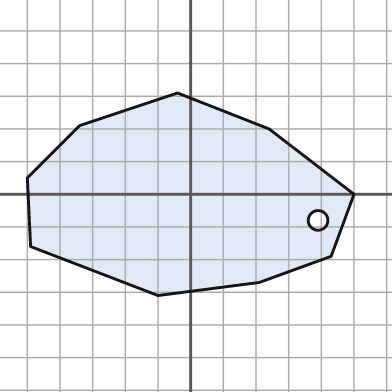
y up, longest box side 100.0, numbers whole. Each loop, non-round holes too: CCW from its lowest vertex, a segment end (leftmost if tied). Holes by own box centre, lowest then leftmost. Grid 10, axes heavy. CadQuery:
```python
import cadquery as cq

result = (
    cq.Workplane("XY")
    .moveTo(-10.0, -31.0)
    .lineTo(21.0, -27.0)
    .lineTo(43.0, -19.0)
    .lineTo(50.0, 0.0)
    .lineTo(24.0, 20.0)
    .lineTo(-4.0, 31.0)
    .lineTo(-34.0, 21.0)
    .lineTo(-50.0, 5.0)
    .lineTo(-49.0, -16.0)
    .close()
    .moveTo(39.0, -8.0)
    .circle(3.0)
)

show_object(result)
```